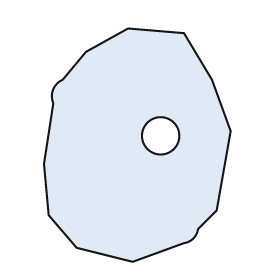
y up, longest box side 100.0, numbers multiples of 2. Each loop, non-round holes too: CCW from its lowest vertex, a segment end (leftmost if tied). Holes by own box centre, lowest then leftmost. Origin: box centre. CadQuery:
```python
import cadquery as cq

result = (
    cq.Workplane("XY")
    .moveTo(-2.0, -50.0)
    .lineTo(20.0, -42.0)
    .threePointArc((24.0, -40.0), (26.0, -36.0))
    .lineTo(34.0, -28.0)
    .lineTo(40.0, 6.0)
    .lineTo(32.0, 28.0)
    .lineTo(20.0, 48.0)
    .lineTo(-4.0, 50.0)
    .lineTo(-22.0, 40.0)
    .lineTo(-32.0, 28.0)
    .threePointArc((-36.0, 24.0), (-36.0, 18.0))
    .lineTo(-40.0, -8.0)
    .lineTo(-38.0, -30.0)
    .lineTo(-26.0, -44.0)
    .close()
    .moveTo(10.0, 4.0)
    .circle(8.0)
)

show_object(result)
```